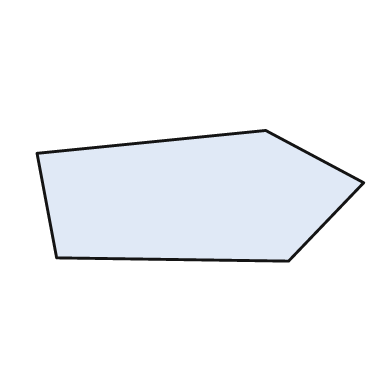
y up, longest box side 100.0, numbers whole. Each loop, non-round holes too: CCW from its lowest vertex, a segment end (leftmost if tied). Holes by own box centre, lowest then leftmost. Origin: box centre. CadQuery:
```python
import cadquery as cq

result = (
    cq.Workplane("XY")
    .moveTo(27.0, -20.0)
    .lineTo(50.0, 4.0)
    .lineTo(20.0, 20.0)
    .lineTo(-50.0, 13.0)
    .lineTo(-44.0, -19.0)
    .close()
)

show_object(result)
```